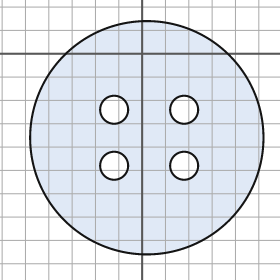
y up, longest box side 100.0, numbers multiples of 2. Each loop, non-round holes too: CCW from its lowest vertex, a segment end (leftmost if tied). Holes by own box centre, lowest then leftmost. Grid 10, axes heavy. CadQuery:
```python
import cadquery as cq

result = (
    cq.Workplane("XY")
    .moveTo(2.0, -36.0)
    .circle(50.0)
    .moveTo(-12.0, -48.0)
    .circle(6.0)
    .moveTo(18.0, -48.0)
    .circle(6.0)
    .moveTo(-12.0, -24.0)
    .circle(6.0)
    .moveTo(18.0, -24.0)
    .circle(6.0)
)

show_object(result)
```